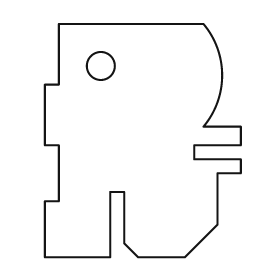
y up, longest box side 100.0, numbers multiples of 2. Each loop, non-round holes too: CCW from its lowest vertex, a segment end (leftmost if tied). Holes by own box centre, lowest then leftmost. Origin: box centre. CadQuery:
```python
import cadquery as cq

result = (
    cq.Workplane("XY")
    .moveTo(-42.0, -50.0)
    .lineTo(-14.0, -50.0)
    .lineTo(-14.0, -22.0)
    .lineTo(-8.0, -22.0)
    .lineTo(-8.0, -44.0)
    .lineTo(-2.0, -50.0)
    .lineTo(18.0, -50.0)
    .lineTo(32.0, -36.0)
    .lineTo(32.0, -14.0)
    .lineTo(42.0, -14.0)
    .lineTo(42.0, -8.0)
    .lineTo(22.0, -8.0)
    .lineTo(22.0, -2.0)
    .lineTo(42.0, -2.0)
    .lineTo(42.0, 6.0)
    .lineTo(26.0, 6.0)
    .threePointArc((34.0, 28.0), (26.0, 50.0))
    .lineTo(-36.0, 50.0)
    .lineTo(-36.0, 24.0)
    .lineTo(-42.0, 24.0)
    .lineTo(-42.0, -2.0)
    .lineTo(-36.0, -2.0)
    .lineTo(-36.0, -26.0)
    .lineTo(-42.0, -26.0)
    .close()
    .moveTo(-18.0, 32.0)
    .circle(6.0)
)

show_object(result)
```